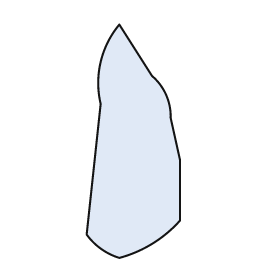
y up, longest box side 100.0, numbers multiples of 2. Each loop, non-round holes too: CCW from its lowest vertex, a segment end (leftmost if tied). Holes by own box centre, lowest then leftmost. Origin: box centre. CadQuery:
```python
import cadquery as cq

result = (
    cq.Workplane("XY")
    .moveTo(-6.0, -50.0)
    .threePointArc((8.0, -44.0), (20.0, -34.0))
    .lineTo(20.0, -8.0)
    .lineTo(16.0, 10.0)
    .threePointArc((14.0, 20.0), (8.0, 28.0))
    .lineTo(-6.0, 50.0)
    .threePointArc((-14.0, 34.0), (-14.0, 16.0))
    .lineTo(-20.0, -40.0)
    .threePointArc((-14.0, -46.0), (-6.0, -50.0))
    .close()
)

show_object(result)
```